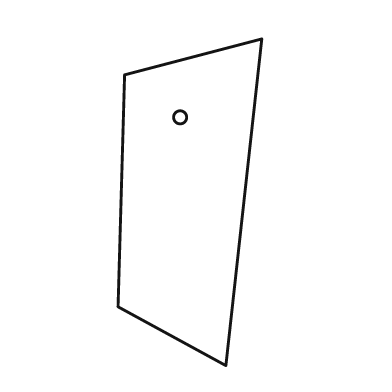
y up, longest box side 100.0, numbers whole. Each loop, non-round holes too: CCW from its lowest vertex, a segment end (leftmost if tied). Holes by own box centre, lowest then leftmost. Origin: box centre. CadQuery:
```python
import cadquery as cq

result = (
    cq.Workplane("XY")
    .moveTo(11.0, -50.0)
    .lineTo(22.0, 50.0)
    .lineTo(-20.0, 39.0)
    .lineTo(-22.0, -32.0)
    .close()
    .moveTo(-3.0, 26.0)
    .circle(2.0)
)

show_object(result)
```